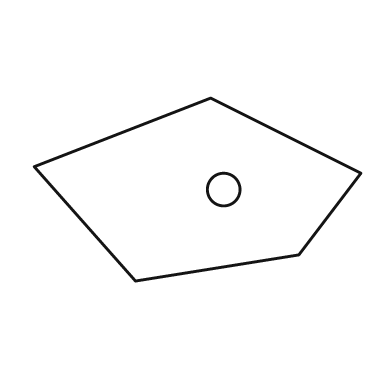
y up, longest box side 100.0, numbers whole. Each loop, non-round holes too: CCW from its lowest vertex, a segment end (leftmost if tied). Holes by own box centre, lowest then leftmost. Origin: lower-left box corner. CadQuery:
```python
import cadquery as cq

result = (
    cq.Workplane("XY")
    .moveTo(31.0, 0.0)
    .lineTo(81.0, 8.0)
    .lineTo(100.0, 33.0)
    .lineTo(54.0, 56.0)
    .lineTo(0.0, 35.0)
    .close()
    .moveTo(58.0, 28.0)
    .circle(5.0)
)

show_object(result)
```